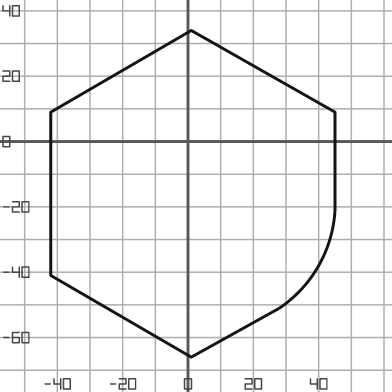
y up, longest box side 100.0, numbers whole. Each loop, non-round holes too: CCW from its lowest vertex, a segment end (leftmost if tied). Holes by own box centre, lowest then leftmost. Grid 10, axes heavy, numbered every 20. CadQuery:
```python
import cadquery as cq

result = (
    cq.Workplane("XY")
    .moveTo(1.0, -66.0)
    .lineTo(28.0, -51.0)
    .threePointArc((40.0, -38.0), (45.0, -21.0))
    .lineTo(45.0, 9.0)
    .lineTo(1.0, 34.0)
    .lineTo(-42.0, 9.0)
    .lineTo(-42.0, -41.0)
    .close()
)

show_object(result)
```